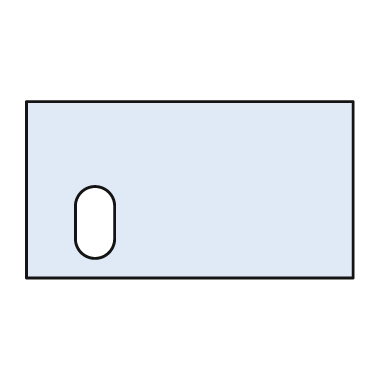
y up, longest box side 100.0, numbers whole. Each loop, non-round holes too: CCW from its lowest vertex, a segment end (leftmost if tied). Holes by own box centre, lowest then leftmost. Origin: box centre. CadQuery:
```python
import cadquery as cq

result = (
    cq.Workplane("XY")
    .moveTo(-50.0, -27.0)
    .lineTo(50.0, -27.0)
    .lineTo(50.0, 27.0)
    .lineTo(-50.0, 27.0)
    .close()
    .moveTo(-35.0, -15.0)
    .threePointArc((-29.0, -21.0), (-23.0, -15.0))
    .lineTo(-23.0, -5.0)
    .threePointArc((-29.0, 1.0), (-35.0, -5.0))
    .close()
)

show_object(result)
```